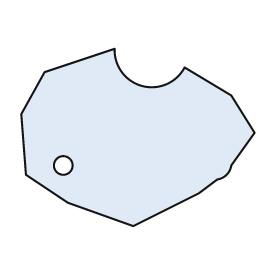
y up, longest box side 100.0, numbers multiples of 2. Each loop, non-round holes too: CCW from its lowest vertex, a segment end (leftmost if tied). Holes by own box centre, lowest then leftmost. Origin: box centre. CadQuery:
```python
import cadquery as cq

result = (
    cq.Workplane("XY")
    .moveTo(-2.0, -38.0)
    .lineTo(26.0, -24.0)
    .lineTo(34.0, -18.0)
    .threePointArc((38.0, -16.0), (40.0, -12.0))
    .lineTo(50.0, 2.0)
    .lineTo(40.0, 18.0)
    .lineTo(20.0, 30.0)
    .threePointArc((2.0, 22.0), (-10.0, 38.0))
    .lineTo(-40.0, 28.0)
    .lineTo(-50.0, 10.0)
    .lineTo(-48.0, -16.0)
    .lineTo(-30.0, -28.0)
    .close()
    .moveTo(-32.0, -12.0)
    .circle(4.0)
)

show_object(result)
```